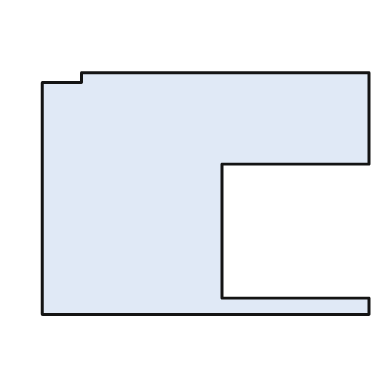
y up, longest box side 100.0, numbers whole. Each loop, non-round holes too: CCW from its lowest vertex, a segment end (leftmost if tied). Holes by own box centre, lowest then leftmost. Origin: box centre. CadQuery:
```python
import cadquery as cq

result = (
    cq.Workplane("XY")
    .moveTo(-50.0, -37.0)
    .lineTo(50.0, -37.0)
    .lineTo(50.0, -32.0)
    .lineTo(5.0, -32.0)
    .lineTo(5.0, 9.0)
    .lineTo(50.0, 9.0)
    .lineTo(50.0, 37.0)
    .lineTo(-38.0, 37.0)
    .lineTo(-38.0, 34.0)
    .lineTo(-50.0, 34.0)
    .close()
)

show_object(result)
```